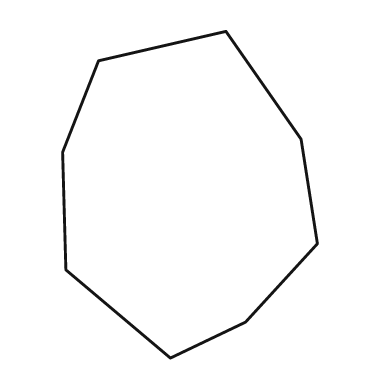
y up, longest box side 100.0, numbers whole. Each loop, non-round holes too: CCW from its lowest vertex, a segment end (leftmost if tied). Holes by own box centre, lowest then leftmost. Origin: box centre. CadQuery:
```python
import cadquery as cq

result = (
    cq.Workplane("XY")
    .moveTo(-6.0, -50.0)
    .lineTo(17.0, -39.0)
    .lineTo(39.0, -15.0)
    .lineTo(34.0, 17.0)
    .lineTo(11.0, 50.0)
    .lineTo(-28.0, 41.0)
    .lineTo(-39.0, 13.0)
    .lineTo(-38.0, -23.0)
    .close()
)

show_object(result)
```